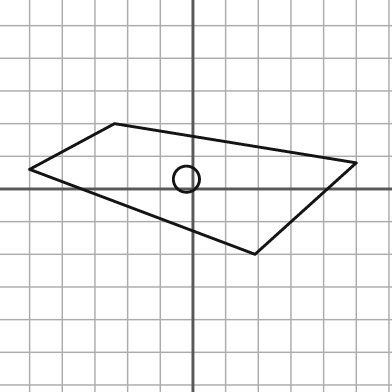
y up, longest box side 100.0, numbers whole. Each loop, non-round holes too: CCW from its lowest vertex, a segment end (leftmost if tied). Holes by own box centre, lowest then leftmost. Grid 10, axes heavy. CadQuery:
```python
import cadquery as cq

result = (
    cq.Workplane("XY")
    .moveTo(19.0, -20.0)
    .lineTo(50.0, 8.0)
    .lineTo(-24.0, 20.0)
    .lineTo(-50.0, 6.0)
    .close()
    .moveTo(-2.0, 3.0)
    .circle(4.0)
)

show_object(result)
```